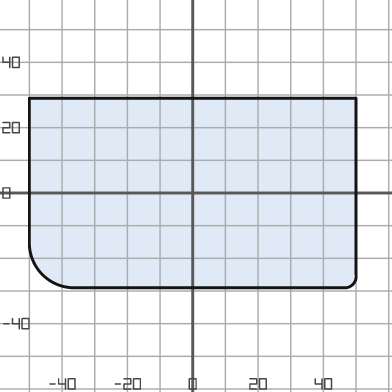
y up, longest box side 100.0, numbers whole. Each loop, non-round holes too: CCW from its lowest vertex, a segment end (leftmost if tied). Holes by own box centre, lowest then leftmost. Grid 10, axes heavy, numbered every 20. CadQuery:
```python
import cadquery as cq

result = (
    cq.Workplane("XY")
    .moveTo(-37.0, -29.0)
    .lineTo(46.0, -29.0)
    .threePointArc((49.0, -28.0), (50.0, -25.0))
    .lineTo(50.0, 29.0)
    .lineTo(-50.0, 29.0)
    .lineTo(-50.0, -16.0)
    .threePointArc((-46.0, -25.0), (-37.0, -29.0))
    .close()
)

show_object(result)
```